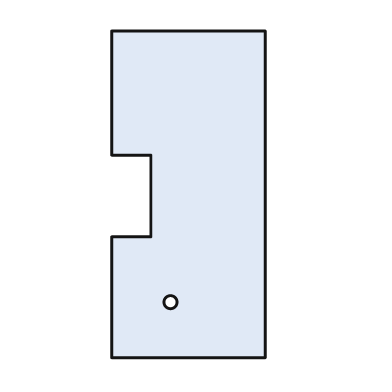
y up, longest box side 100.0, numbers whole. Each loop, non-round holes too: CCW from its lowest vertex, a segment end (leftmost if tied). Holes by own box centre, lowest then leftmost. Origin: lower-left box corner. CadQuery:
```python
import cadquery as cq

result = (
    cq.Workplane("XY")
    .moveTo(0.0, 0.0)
    .lineTo(47.0, 0.0)
    .lineTo(47.0, 100.0)
    .lineTo(0.0, 100.0)
    .lineTo(0.0, 62.0)
    .lineTo(12.0, 62.0)
    .lineTo(12.0, 37.0)
    .lineTo(0.0, 37.0)
    .close()
    .moveTo(18.0, 17.0)
    .circle(2.0)
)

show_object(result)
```